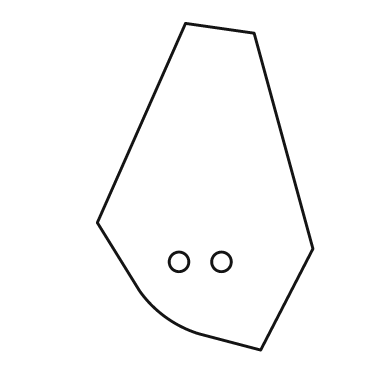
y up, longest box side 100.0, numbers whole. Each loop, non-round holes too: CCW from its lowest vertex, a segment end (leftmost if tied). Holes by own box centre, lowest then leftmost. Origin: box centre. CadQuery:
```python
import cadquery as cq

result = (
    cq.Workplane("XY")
    .moveTo(17.0, -50.0)
    .lineTo(33.0, -19.0)
    .lineTo(15.0, 47.0)
    .lineTo(-6.0, 50.0)
    .lineTo(-33.0, -11.0)
    .lineTo(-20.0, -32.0)
    .threePointArc((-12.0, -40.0), (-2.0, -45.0))
    .close()
    .moveTo(-8.0, -23.0)
    .circle(3.0)
    .moveTo(5.0, -23.0)
    .circle(3.0)
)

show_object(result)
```